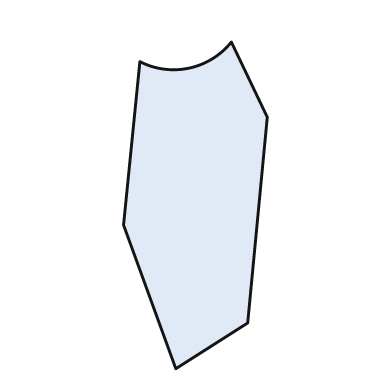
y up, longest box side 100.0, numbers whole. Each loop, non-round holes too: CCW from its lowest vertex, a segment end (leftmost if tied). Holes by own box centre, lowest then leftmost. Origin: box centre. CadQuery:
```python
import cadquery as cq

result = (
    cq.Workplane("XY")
    .moveTo(-6.0, -50.0)
    .lineTo(16.0, -36.0)
    .lineTo(22.0, 27.0)
    .lineTo(11.0, 50.0)
    .threePointArc((-2.0, 42.0), (-17.0, 44.0))
    .lineTo(-22.0, -6.0)
    .close()
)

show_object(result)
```